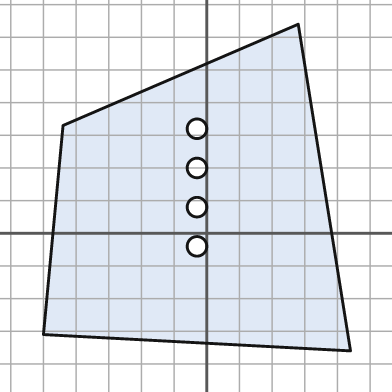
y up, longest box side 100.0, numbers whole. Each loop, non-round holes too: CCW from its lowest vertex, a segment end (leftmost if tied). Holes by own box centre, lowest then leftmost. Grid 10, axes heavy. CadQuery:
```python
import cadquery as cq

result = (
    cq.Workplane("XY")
    .moveTo(44.0, -36.0)
    .lineTo(28.0, 64.0)
    .lineTo(-44.0, 33.0)
    .lineTo(-50.0, -31.0)
    .close()
    .moveTo(-3.0, -4.0)
    .circle(3.0)
    .moveTo(-3.0, 8.0)
    .circle(3.0)
    .moveTo(-3.0, 20.0)
    .circle(3.0)
    .moveTo(-3.0, 32.0)
    .circle(3.0)
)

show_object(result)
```